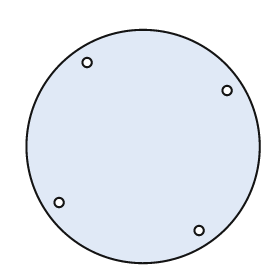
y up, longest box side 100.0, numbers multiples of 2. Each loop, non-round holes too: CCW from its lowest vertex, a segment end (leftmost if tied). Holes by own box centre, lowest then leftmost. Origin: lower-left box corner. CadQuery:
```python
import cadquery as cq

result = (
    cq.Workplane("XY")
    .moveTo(50.0, 50.0)
    .circle(50.0)
    .moveTo(74.0, 14.0)
    .circle(2.0)
    .moveTo(14.0, 26.0)
    .circle(2.0)
    .moveTo(86.0, 74.0)
    .circle(2.0)
    .moveTo(26.0, 86.0)
    .circle(2.0)
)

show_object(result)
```